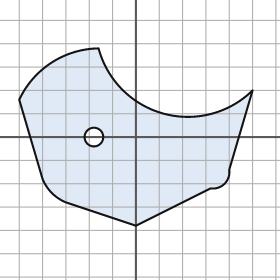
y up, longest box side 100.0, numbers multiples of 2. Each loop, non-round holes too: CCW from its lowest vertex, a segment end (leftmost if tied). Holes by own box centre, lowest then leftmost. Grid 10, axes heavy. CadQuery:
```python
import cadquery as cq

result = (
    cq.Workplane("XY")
    .moveTo(0.0, -38.0)
    .lineTo(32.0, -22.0)
    .threePointArc((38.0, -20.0), (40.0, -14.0))
    .lineTo(50.0, 20.0)
    .threePointArc((12.0, 10.0), (-16.0, 38.0))
    .threePointArc((-36.0, 32.0), (-50.0, 16.0))
    .lineTo(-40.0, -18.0)
    .threePointArc((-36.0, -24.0), (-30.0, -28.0))
    .close()
    .moveTo(-18.0, 0.0)
    .circle(4.0)
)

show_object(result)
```